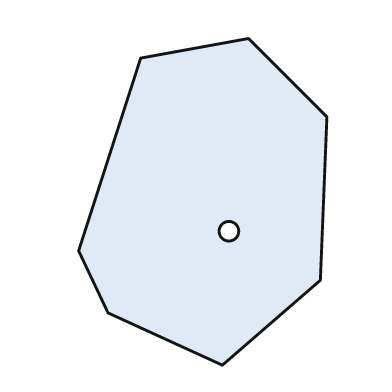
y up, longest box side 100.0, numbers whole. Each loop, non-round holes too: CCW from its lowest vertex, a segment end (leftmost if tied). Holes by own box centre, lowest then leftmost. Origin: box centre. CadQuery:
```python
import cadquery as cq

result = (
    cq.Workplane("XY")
    .moveTo(6.0, -50.0)
    .lineTo(36.0, -24.0)
    .lineTo(38.0, 26.0)
    .lineTo(14.0, 50.0)
    .lineTo(-19.0, 44.0)
    .lineTo(-38.0, -15.0)
    .lineTo(-29.0, -34.0)
    .close()
    .moveTo(8.0, -9.0)
    .circle(3.0)
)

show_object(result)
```